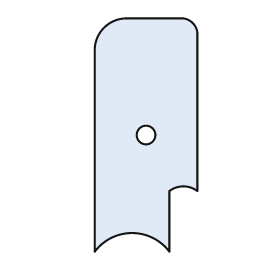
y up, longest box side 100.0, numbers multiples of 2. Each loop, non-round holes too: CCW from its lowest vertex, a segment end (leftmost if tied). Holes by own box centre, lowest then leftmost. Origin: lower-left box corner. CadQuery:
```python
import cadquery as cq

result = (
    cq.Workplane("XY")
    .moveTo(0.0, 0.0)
    .threePointArc((16.0, 8.0), (32.0, 0.0))
    .lineTo(32.0, 26.0)
    .threePointArc((38.0, 28.0), (44.0, 26.0))
    .lineTo(44.0, 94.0)
    .threePointArc((42.0, 98.0), (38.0, 100.0))
    .lineTo(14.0, 100.0)
    .threePointArc((4.0, 96.0), (0.0, 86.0))
    .close()
    .moveTo(22.0, 50.0)
    .circle(4.0)
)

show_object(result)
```